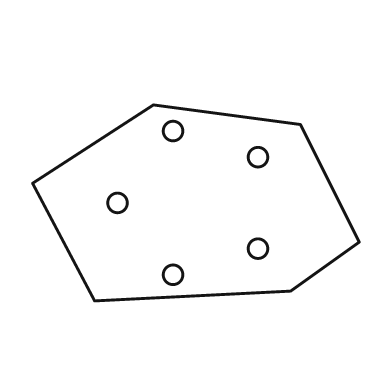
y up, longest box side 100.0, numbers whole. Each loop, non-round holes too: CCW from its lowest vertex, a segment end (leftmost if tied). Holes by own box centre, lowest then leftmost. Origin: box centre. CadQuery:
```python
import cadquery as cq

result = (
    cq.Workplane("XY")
    .moveTo(-31.0, -30.0)
    .lineTo(29.0, -27.0)
    .lineTo(50.0, -12.0)
    .lineTo(32.0, 24.0)
    .lineTo(-13.0, 30.0)
    .lineTo(-50.0, 6.0)
    .close()
    .moveTo(-7.0, -22.0)
    .circle(3.0)
    .moveTo(19.0, -14.0)
    .circle(3.0)
    .moveTo(-24.0, 0.0)
    .circle(3.0)
    .moveTo(19.0, 14.0)
    .circle(3.0)
    .moveTo(-7.0, 22.0)
    .circle(3.0)
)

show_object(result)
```